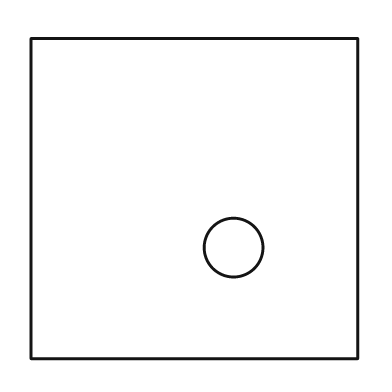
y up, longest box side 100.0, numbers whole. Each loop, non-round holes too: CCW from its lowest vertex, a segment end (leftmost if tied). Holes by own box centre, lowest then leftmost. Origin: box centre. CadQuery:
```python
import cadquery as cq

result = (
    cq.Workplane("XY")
    .moveTo(-50.0, -49.0)
    .lineTo(50.0, -49.0)
    .lineTo(50.0, 49.0)
    .lineTo(-50.0, 49.0)
    .close()
    .moveTo(12.0, -15.0)
    .circle(9.0)
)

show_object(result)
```